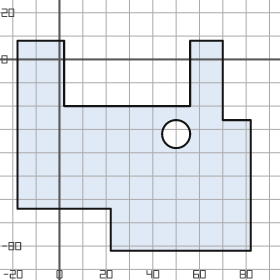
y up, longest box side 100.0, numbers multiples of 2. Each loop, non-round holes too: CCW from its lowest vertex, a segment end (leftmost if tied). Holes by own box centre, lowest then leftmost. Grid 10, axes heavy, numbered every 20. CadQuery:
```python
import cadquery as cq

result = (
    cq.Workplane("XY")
    .moveTo(22.0, -82.0)
    .lineTo(82.0, -82.0)
    .lineTo(82.0, -26.0)
    .lineTo(70.0, -26.0)
    .lineTo(70.0, 8.0)
    .lineTo(56.0, 8.0)
    .lineTo(56.0, -20.0)
    .lineTo(2.0, -20.0)
    .lineTo(2.0, 8.0)
    .lineTo(-18.0, 8.0)
    .lineTo(-18.0, -64.0)
    .lineTo(22.0, -64.0)
    .close()
    .moveTo(50.0, -32.0)
    .circle(6.0)
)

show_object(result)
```